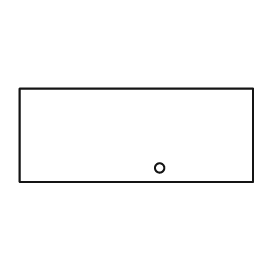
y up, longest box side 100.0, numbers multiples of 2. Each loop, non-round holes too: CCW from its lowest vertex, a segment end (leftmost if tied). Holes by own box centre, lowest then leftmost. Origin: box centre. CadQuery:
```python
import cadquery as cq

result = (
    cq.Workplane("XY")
    .moveTo(-50.0, -20.0)
    .lineTo(50.0, -20.0)
    .lineTo(50.0, 20.0)
    .lineTo(-50.0, 20.0)
    .close()
    .moveTo(10.0, -14.0)
    .circle(2.0)
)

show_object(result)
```